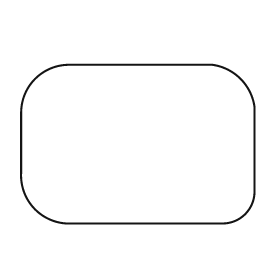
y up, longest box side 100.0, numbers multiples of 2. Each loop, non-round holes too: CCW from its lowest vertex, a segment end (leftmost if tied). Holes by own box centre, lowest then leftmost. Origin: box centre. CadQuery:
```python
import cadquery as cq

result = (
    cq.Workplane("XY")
    .moveTo(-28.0, -34.0)
    .lineTo(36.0, -34.0)
    .threePointArc((46.0, -30.0), (50.0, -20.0))
    .lineTo(50.0, 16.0)
    .threePointArc((44.0, 28.0), (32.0, 34.0))
    .lineTo(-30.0, 34.0)
    .threePointArc((-44.0, 28.0), (-50.0, 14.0))
    .lineTo(-50.0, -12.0)
    .threePointArc((-44.0, -28.0), (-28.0, -34.0))
    .close()
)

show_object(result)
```